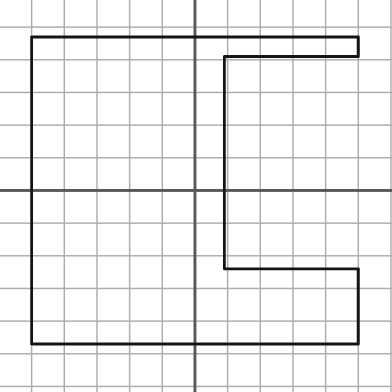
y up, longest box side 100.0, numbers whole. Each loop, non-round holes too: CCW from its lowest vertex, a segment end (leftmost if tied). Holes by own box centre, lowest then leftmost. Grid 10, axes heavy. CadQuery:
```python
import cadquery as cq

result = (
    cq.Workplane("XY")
    .moveTo(-50.0, -47.0)
    .lineTo(50.0, -47.0)
    .lineTo(50.0, -24.0)
    .lineTo(9.0, -24.0)
    .lineTo(9.0, 41.0)
    .lineTo(50.0, 41.0)
    .lineTo(50.0, 47.0)
    .lineTo(-50.0, 47.0)
    .close()
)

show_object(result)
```